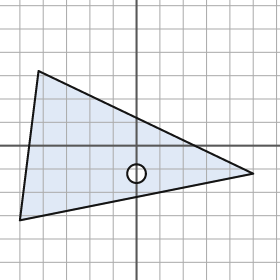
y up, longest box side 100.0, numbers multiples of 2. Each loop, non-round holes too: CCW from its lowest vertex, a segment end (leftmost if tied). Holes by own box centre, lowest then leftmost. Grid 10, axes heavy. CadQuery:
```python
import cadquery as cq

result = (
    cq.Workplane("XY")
    .moveTo(-50.0, -32.0)
    .lineTo(50.0, -12.0)
    .lineTo(-42.0, 32.0)
    .close()
    .moveTo(0.0, -12.0)
    .circle(4.0)
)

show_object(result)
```